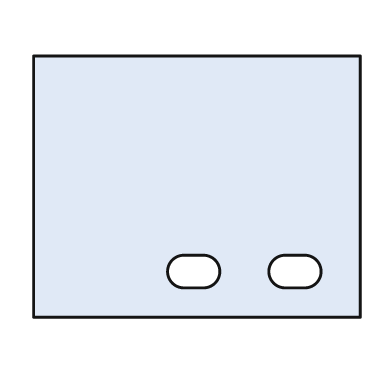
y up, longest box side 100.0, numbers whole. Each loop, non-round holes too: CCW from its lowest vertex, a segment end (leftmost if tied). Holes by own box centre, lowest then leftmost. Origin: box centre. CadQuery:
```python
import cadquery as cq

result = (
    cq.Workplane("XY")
    .moveTo(-50.0, -40.0)
    .lineTo(50.0, -40.0)
    .lineTo(50.0, 40.0)
    .lineTo(-50.0, 40.0)
    .close()
    .moveTo(-4.0, -31.0)
    .lineTo(2.0, -31.0)
    .threePointArc((7.0, -26.0), (2.0, -21.0))
    .lineTo(-4.0, -21.0)
    .threePointArc((-9.0, -26.0), (-4.0, -31.0))
    .close()
    .moveTo(27.0, -31.0)
    .lineTo(33.0, -31.0)
    .threePointArc((38.0, -26.0), (33.0, -21.0))
    .lineTo(27.0, -21.0)
    .threePointArc((22.0, -26.0), (27.0, -31.0))
    .close()
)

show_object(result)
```